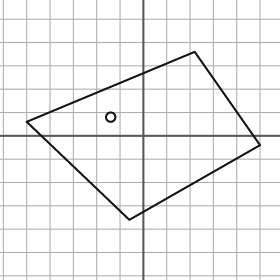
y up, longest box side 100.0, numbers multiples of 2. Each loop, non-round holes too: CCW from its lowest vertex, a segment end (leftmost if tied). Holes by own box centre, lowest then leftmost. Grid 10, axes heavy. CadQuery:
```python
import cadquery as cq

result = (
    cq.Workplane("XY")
    .moveTo(-6.0, -36.0)
    .lineTo(50.0, -4.0)
    .lineTo(22.0, 36.0)
    .lineTo(-50.0, 6.0)
    .close()
    .moveTo(-14.0, 8.0)
    .circle(2.0)
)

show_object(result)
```